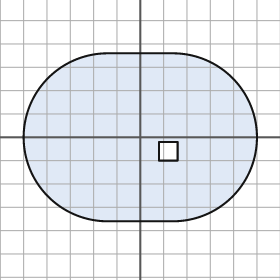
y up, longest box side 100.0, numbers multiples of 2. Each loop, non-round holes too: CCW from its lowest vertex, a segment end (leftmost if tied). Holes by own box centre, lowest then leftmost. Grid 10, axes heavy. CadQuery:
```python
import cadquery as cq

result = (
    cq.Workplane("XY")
    .moveTo(-14.0, -36.0)
    .lineTo(14.0, -36.0)
    .threePointArc((50.0, 0.0), (14.0, 36.0))
    .lineTo(-14.0, 36.0)
    .threePointArc((-50.0, 0.0), (-14.0, -36.0))
    .close()
    .moveTo(8.0, -10.0)
    .lineTo(16.0, -10.0)
    .lineTo(16.0, -2.0)
    .lineTo(8.0, -2.0)
    .close()
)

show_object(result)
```